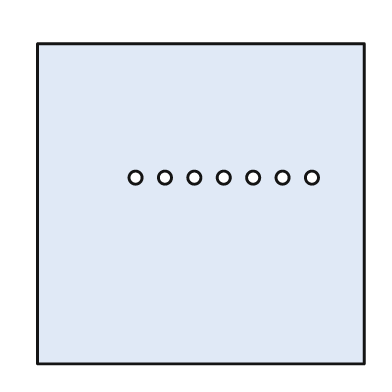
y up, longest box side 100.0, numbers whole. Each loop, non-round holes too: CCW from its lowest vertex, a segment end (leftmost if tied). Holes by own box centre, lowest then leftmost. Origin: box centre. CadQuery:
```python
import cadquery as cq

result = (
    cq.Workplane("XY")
    .moveTo(-50.0, -49.0)
    .lineTo(50.0, -49.0)
    .lineTo(50.0, 49.0)
    .lineTo(-50.0, 49.0)
    .close()
    .moveTo(-20.0, 8.0)
    .circle(2.0)
    .moveTo(-11.0, 8.0)
    .circle(2.0)
    .moveTo(-2.0, 8.0)
    .circle(2.0)
    .moveTo(7.0, 8.0)
    .circle(2.0)
    .moveTo(16.0, 8.0)
    .circle(2.0)
    .moveTo(25.0, 8.0)
    .circle(2.0)
    .moveTo(34.0, 8.0)
    .circle(2.0)
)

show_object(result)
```